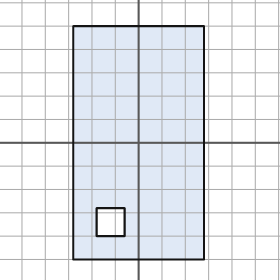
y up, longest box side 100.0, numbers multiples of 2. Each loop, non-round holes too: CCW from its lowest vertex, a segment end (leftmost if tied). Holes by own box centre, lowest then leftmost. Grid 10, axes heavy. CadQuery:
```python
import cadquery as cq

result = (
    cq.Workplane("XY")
    .moveTo(-28.0, -50.0)
    .lineTo(28.0, -50.0)
    .lineTo(28.0, 50.0)
    .lineTo(-28.0, 50.0)
    .close()
    .moveTo(-18.0, -40.0)
    .lineTo(-6.0, -40.0)
    .lineTo(-6.0, -28.0)
    .lineTo(-18.0, -28.0)
    .close()
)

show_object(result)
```